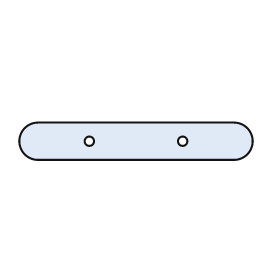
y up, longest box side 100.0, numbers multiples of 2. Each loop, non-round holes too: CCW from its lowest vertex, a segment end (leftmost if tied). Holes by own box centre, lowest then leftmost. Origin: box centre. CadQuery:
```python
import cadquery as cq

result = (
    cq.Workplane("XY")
    .moveTo(-42.0, -8.0)
    .lineTo(42.0, -8.0)
    .threePointArc((50.0, 0.0), (42.0, 8.0))
    .lineTo(-42.0, 8.0)
    .threePointArc((-50.0, 0.0), (-42.0, -8.0))
    .close()
    .moveTo(-20.0, 0.0)
    .circle(2.0)
    .moveTo(20.0, 0.0)
    .circle(2.0)
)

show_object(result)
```